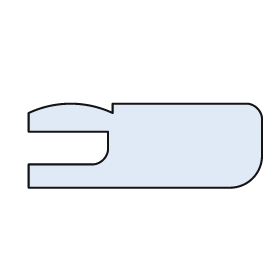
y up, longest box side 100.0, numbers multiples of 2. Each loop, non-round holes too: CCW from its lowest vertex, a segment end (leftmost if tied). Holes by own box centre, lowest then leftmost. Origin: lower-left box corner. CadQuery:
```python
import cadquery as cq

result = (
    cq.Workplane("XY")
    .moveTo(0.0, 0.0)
    .lineTo(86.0, 0.0)
    .threePointArc((96.0, 4.0), (100.0, 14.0))
    .lineTo(100.0, 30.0)
    .threePointArc((98.0, 34.0), (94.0, 36.0))
    .lineTo(36.0, 36.0)
    .lineTo(36.0, 32.0)
    .threePointArc((18.0, 36.0), (0.0, 32.0))
    .lineTo(0.0, 24.0)
    .lineTo(34.0, 24.0)
    .lineTo(34.0, 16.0)
    .threePointArc((32.0, 12.0), (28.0, 10.0))
    .lineTo(0.0, 10.0)
    .close()
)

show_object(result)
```